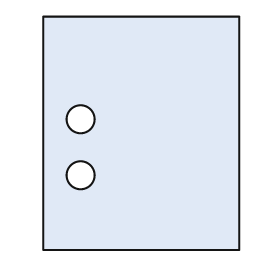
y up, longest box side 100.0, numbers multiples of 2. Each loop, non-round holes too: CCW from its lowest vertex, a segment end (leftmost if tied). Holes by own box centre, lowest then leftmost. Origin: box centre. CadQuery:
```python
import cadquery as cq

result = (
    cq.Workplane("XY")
    .moveTo(-42.0, -50.0)
    .lineTo(42.0, -50.0)
    .lineTo(42.0, 50.0)
    .lineTo(-42.0, 50.0)
    .close()
    .moveTo(-26.0, -18.0)
    .circle(6.0)
    .moveTo(-26.0, 6.0)
    .circle(6.0)
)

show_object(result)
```